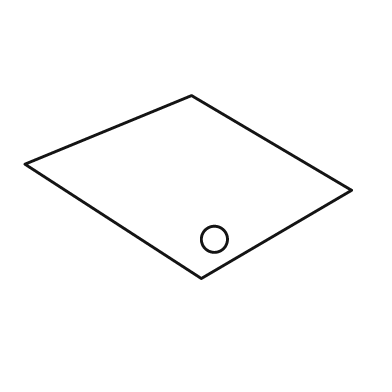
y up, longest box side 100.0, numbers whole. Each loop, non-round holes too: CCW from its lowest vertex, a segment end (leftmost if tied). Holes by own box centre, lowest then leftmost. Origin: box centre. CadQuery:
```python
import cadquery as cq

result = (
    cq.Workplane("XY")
    .moveTo(4.0, -28.0)
    .lineTo(50.0, -1.0)
    .lineTo(1.0, 28.0)
    .lineTo(-50.0, 7.0)
    .close()
    .moveTo(8.0, -16.0)
    .circle(4.0)
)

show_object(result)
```